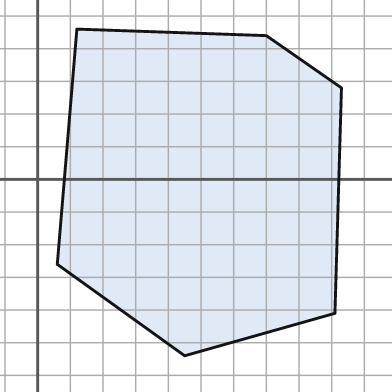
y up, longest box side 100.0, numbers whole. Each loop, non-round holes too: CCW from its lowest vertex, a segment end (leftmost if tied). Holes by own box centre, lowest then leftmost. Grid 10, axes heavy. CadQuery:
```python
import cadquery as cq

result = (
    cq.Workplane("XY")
    .moveTo(45.0, -54.0)
    .lineTo(91.0, -41.0)
    .lineTo(93.0, 28.0)
    .lineTo(70.0, 44.0)
    .lineTo(12.0, 46.0)
    .lineTo(6.0, -26.0)
    .close()
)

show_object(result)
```